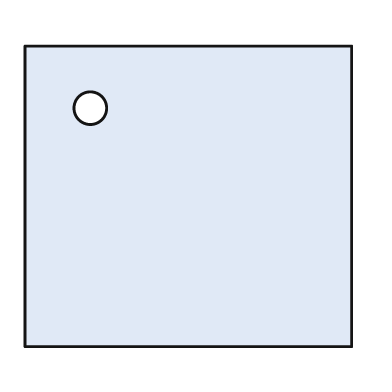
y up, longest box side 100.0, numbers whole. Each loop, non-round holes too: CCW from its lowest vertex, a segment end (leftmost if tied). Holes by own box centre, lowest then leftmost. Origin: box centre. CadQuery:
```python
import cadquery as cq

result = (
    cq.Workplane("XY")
    .moveTo(-50.0, -46.0)
    .lineTo(50.0, -46.0)
    .lineTo(50.0, 46.0)
    .lineTo(-50.0, 46.0)
    .close()
    .moveTo(-30.0, 27.0)
    .circle(5.0)
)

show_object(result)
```